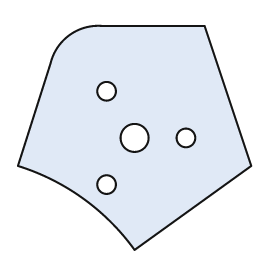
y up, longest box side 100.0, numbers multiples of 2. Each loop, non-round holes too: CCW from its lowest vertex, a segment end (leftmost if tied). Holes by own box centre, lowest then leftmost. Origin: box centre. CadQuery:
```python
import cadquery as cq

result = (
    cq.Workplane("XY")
    .moveTo(0.0, -48.0)
    .lineTo(50.0, -12.0)
    .lineTo(30.0, 48.0)
    .lineTo(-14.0, 48.0)
    .threePointArc((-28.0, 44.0), (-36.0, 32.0))
    .lineTo(-50.0, -12.0)
    .threePointArc((-22.0, -26.0), (0.0, -48.0))
    .close()
    .moveTo(-12.0, -20.0)
    .circle(4.0)
    .moveTo(0.0, 0.0)
    .circle(6.0)
    .moveTo(22.0, 0.0)
    .circle(4.0)
    .moveTo(-12.0, 20.0)
    .circle(4.0)
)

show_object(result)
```